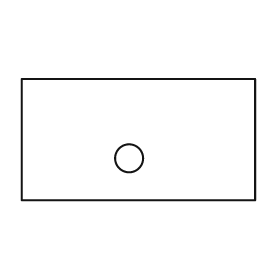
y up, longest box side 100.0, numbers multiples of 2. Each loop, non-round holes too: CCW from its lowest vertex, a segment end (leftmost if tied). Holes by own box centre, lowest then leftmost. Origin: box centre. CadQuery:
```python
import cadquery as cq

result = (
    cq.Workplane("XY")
    .moveTo(-50.0, -26.0)
    .lineTo(50.0, -26.0)
    .lineTo(50.0, 26.0)
    .lineTo(-50.0, 26.0)
    .close()
    .moveTo(-4.0, -8.0)
    .circle(6.0)
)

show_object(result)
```